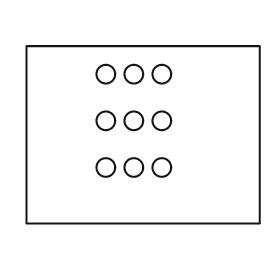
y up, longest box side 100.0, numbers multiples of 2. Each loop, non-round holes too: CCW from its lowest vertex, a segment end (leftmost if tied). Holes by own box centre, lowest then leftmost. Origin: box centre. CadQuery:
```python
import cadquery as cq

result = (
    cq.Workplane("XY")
    .moveTo(-50.0, -38.0)
    .lineTo(50.0, -38.0)
    .lineTo(50.0, 38.0)
    .lineTo(-50.0, 38.0)
    .close()
    .moveTo(-16.0, -14.0)
    .circle(4.0)
    .moveTo(-4.0, -14.0)
    .circle(4.0)
    .moveTo(8.0, -14.0)
    .circle(4.0)
    .moveTo(-16.0, 6.0)
    .circle(4.0)
    .moveTo(-4.0, 6.0)
    .circle(4.0)
    .moveTo(8.0, 6.0)
    .circle(4.0)
    .moveTo(-16.0, 26.0)
    .circle(4.0)
    .moveTo(-4.0, 26.0)
    .circle(4.0)
    .moveTo(8.0, 26.0)
    .circle(4.0)
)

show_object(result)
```